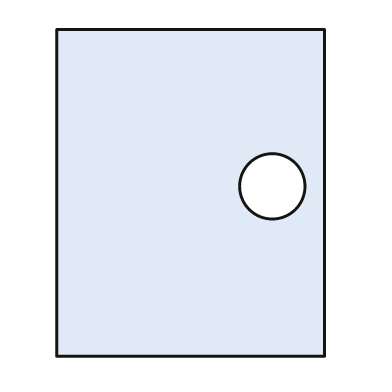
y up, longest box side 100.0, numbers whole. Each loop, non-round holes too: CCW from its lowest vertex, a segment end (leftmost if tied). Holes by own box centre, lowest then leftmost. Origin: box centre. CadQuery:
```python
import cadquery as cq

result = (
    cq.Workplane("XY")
    .moveTo(-41.0, -50.0)
    .lineTo(41.0, -50.0)
    .lineTo(41.0, 50.0)
    .lineTo(-41.0, 50.0)
    .close()
    .moveTo(25.0, 2.0)
    .circle(10.0)
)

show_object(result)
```